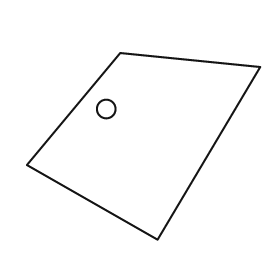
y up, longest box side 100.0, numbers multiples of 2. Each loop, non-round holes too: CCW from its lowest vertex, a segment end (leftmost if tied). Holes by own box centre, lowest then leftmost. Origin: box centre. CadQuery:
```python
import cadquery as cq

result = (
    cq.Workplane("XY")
    .moveTo(6.0, -40.0)
    .lineTo(50.0, 34.0)
    .lineTo(-10.0, 40.0)
    .lineTo(-50.0, -8.0)
    .close()
    .moveTo(-16.0, 16.0)
    .circle(4.0)
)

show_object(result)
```